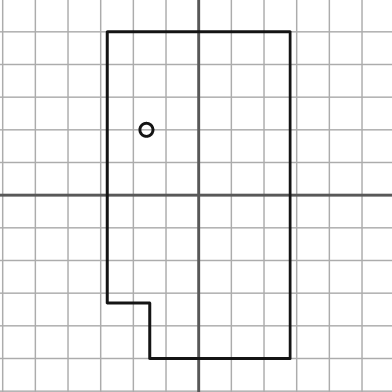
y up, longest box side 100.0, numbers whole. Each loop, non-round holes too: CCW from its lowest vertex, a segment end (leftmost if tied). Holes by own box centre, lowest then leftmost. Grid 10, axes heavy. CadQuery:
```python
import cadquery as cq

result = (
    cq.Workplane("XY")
    .moveTo(-15.0, -50.0)
    .lineTo(28.0, -50.0)
    .lineTo(28.0, 50.0)
    .lineTo(-28.0, 50.0)
    .lineTo(-28.0, -33.0)
    .lineTo(-15.0, -33.0)
    .close()
    .moveTo(-16.0, 20.0)
    .circle(2.0)
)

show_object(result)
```